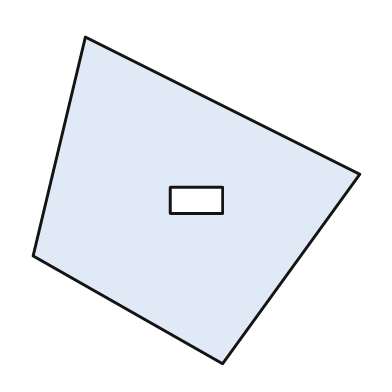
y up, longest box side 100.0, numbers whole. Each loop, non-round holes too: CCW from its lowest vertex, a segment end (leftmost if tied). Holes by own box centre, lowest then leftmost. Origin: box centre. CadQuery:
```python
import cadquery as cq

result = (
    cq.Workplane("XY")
    .moveTo(8.0, -50.0)
    .lineTo(50.0, 8.0)
    .lineTo(-34.0, 50.0)
    .lineTo(-50.0, -17.0)
    .close()
    .moveTo(-8.0, -4.0)
    .lineTo(8.0, -4.0)
    .lineTo(8.0, 4.0)
    .lineTo(-8.0, 4.0)
    .close()
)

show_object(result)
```